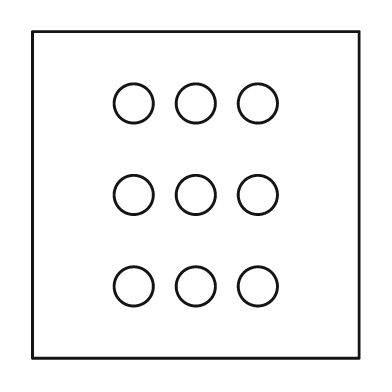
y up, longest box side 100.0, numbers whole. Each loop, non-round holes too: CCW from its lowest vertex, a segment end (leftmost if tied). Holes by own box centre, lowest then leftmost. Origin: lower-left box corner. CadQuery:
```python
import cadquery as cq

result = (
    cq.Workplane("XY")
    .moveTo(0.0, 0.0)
    .lineTo(100.0, 0.0)
    .lineTo(100.0, 100.0)
    .lineTo(0.0, 100.0)
    .close()
    .moveTo(31.0, 22.0)
    .circle(6.0)
    .moveTo(50.0, 22.0)
    .circle(6.0)
    .moveTo(69.0, 22.0)
    .circle(6.0)
    .moveTo(31.0, 50.0)
    .circle(6.0)
    .moveTo(50.0, 50.0)
    .circle(6.0)
    .moveTo(69.0, 50.0)
    .circle(6.0)
    .moveTo(31.0, 78.0)
    .circle(6.0)
    .moveTo(50.0, 78.0)
    .circle(6.0)
    .moveTo(69.0, 78.0)
    .circle(6.0)
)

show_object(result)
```